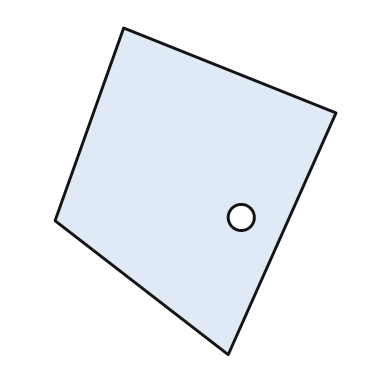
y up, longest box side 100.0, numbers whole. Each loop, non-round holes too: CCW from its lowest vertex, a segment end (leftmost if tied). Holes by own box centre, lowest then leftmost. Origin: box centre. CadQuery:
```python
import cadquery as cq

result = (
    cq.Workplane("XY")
    .moveTo(10.0, -50.0)
    .lineTo(43.0, 24.0)
    .lineTo(-22.0, 50.0)
    .lineTo(-43.0, -9.0)
    .close()
    .moveTo(14.0, -8.0)
    .circle(4.0)
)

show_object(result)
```